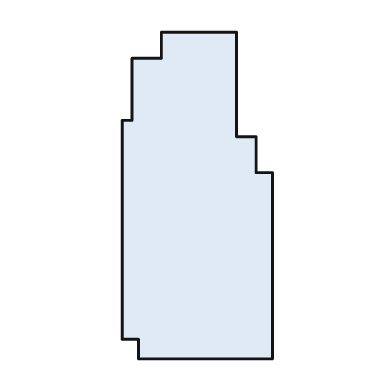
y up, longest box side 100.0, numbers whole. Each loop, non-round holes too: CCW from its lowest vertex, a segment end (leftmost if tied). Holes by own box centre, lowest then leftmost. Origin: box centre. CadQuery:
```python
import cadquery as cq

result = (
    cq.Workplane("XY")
    .moveTo(-18.0, -50.0)
    .lineTo(23.0, -50.0)
    .lineTo(23.0, 7.0)
    .lineTo(18.0, 7.0)
    .lineTo(18.0, 18.0)
    .lineTo(12.0, 18.0)
    .lineTo(12.0, 50.0)
    .lineTo(-11.0, 50.0)
    .lineTo(-11.0, 42.0)
    .lineTo(-20.0, 42.0)
    .lineTo(-20.0, 23.0)
    .lineTo(-23.0, 23.0)
    .lineTo(-23.0, -44.0)
    .lineTo(-18.0, -44.0)
    .close()
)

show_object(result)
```